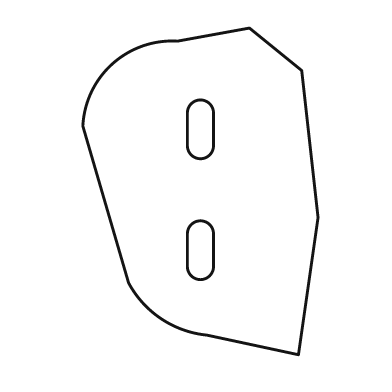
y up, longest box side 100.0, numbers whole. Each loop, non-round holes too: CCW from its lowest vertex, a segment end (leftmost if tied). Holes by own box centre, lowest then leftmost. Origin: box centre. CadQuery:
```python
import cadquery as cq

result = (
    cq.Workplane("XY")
    .moveTo(30.0, -50.0)
    .lineTo(36.0, -8.0)
    .lineTo(31.0, 37.0)
    .lineTo(15.0, 50.0)
    .lineTo(-7.0, 46.0)
    .threePointArc((-27.0, 39.0), (-36.0, 20.0))
    .lineTo(-22.0, -28.0)
    .threePointArc((-12.0, -39.0), (2.0, -44.0))
    .close()
    .moveTo(-4.0, -23.0)
    .threePointArc((0.0, -27.0), (4.0, -23.0))
    .lineTo(4.0, -13.0)
    .threePointArc((0.0, -9.0), (-4.0, -13.0))
    .close()
    .moveTo(-4.0, 14.0)
    .threePointArc((0.0, 10.0), (4.0, 14.0))
    .lineTo(4.0, 24.0)
    .threePointArc((0.0, 28.0), (-4.0, 24.0))
    .close()
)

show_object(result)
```